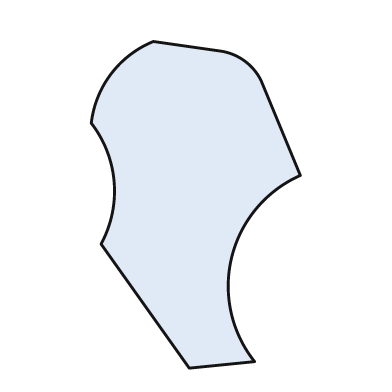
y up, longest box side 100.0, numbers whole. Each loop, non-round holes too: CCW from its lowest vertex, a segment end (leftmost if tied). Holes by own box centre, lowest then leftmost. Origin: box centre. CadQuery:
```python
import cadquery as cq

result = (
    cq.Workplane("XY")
    .moveTo(-2.0, -50.0)
    .lineTo(18.0, -48.0)
    .threePointArc((11.0, -16.0), (32.0, 9.0))
    .lineTo(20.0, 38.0)
    .threePointArc((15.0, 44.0), (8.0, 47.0))
    .lineTo(-13.0, 50.0)
    .threePointArc((-26.0, 40.0), (-32.0, 25.0))
    .threePointArc((-25.0, 7.0), (-29.0, -12.0))
    .close()
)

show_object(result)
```